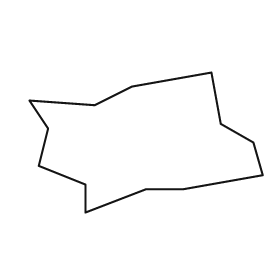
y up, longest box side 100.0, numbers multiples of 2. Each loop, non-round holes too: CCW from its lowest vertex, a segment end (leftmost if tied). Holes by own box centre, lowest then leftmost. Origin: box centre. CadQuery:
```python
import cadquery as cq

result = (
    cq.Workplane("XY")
    .moveTo(-26.0, -30.0)
    .lineTo(0.0, -20.0)
    .lineTo(16.0, -20.0)
    .lineTo(50.0, -14.0)
    .lineTo(46.0, 0.0)
    .lineTo(32.0, 8.0)
    .lineTo(28.0, 30.0)
    .lineTo(-6.0, 24.0)
    .lineTo(-22.0, 16.0)
    .lineTo(-50.0, 18.0)
    .lineTo(-42.0, 6.0)
    .lineTo(-46.0, -10.0)
    .lineTo(-26.0, -18.0)
    .close()
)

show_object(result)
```